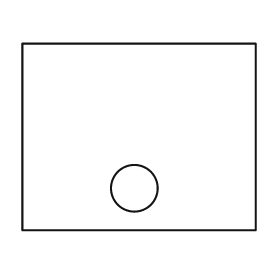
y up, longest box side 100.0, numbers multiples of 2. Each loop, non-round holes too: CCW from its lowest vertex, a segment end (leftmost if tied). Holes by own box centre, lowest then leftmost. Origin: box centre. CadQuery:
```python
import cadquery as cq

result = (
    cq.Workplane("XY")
    .moveTo(-50.0, -40.0)
    .lineTo(50.0, -40.0)
    .lineTo(50.0, 40.0)
    .lineTo(-50.0, 40.0)
    .close()
    .moveTo(-2.0, -22.0)
    .circle(10.0)
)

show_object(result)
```